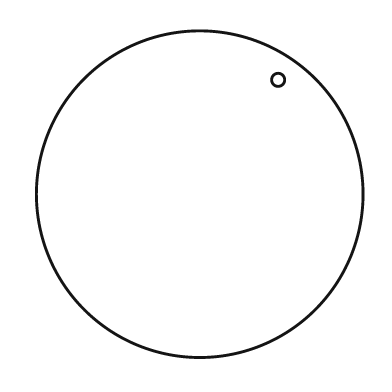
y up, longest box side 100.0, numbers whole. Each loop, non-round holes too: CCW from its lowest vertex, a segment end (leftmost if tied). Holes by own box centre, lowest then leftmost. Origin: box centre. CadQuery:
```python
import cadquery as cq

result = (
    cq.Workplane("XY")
    .moveTo(0.0, 0.0)
    .circle(50.0)
    .moveTo(24.0, 35.0)
    .circle(2.0)
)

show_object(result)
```